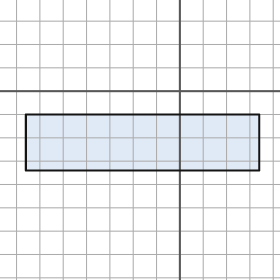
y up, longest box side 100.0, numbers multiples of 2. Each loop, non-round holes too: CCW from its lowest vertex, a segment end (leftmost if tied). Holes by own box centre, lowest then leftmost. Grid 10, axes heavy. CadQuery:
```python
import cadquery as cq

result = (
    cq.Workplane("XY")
    .moveTo(-66.0, -34.0)
    .lineTo(34.0, -34.0)
    .lineTo(34.0, -10.0)
    .lineTo(-66.0, -10.0)
    .close()
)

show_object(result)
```